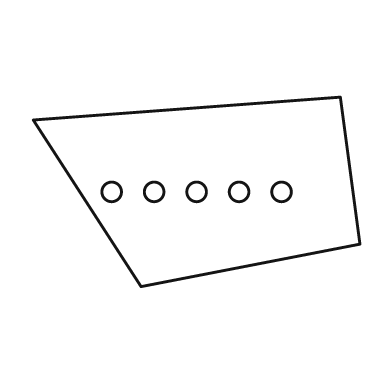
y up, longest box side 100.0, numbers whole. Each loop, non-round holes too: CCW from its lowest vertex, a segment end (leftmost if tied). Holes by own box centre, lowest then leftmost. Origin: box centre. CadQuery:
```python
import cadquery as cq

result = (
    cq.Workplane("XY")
    .moveTo(-17.0, -29.0)
    .lineTo(50.0, -16.0)
    .lineTo(44.0, 29.0)
    .lineTo(-50.0, 22.0)
    .close()
    .moveTo(-26.0, 0.0)
    .circle(3.0)
    .moveTo(-13.0, 0.0)
    .circle(3.0)
    .moveTo(0.0, 0.0)
    .circle(3.0)
    .moveTo(13.0, 0.0)
    .circle(3.0)
    .moveTo(26.0, 0.0)
    .circle(3.0)
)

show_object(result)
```